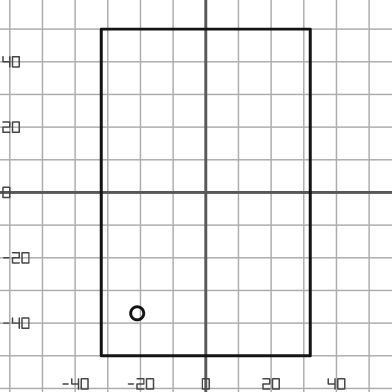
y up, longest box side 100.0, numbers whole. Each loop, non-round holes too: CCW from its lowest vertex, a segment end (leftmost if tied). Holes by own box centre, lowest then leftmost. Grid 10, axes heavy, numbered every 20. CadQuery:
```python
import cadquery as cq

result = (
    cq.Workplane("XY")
    .moveTo(-32.0, -50.0)
    .lineTo(32.0, -50.0)
    .lineTo(32.0, 50.0)
    .lineTo(-32.0, 50.0)
    .close()
    .moveTo(-21.0, -37.0)
    .circle(2.0)
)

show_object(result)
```